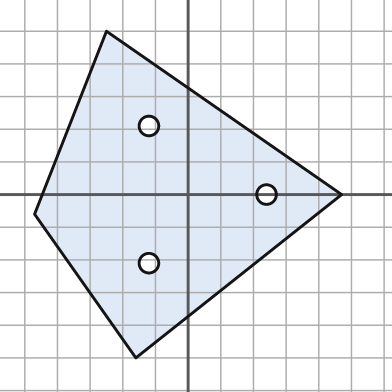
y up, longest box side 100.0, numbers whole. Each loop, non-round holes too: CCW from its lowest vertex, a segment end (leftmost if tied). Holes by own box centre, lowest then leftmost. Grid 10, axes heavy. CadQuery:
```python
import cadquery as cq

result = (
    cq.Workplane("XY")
    .moveTo(-16.0, -50.0)
    .lineTo(47.0, 0.0)
    .lineTo(-25.0, 50.0)
    .lineTo(-47.0, -6.0)
    .close()
    .moveTo(-12.0, -21.0)
    .circle(3.0)
    .moveTo(24.0, 0.0)
    .circle(3.0)
    .moveTo(-12.0, 21.0)
    .circle(3.0)
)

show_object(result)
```